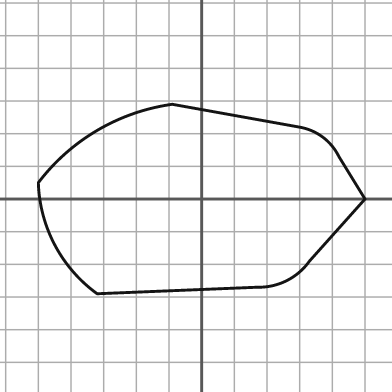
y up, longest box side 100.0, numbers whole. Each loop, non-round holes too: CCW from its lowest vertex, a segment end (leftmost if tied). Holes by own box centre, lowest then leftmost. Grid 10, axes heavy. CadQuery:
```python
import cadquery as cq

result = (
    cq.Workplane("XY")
    .moveTo(-32.0, -29.0)
    .lineTo(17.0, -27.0)
    .threePointArc((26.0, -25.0), (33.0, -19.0))
    .lineTo(50.0, 0.0)
    .lineTo(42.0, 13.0)
    .threePointArc((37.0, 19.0), (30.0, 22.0))
    .lineTo(-9.0, 29.0)
    .threePointArc((-32.0, 21.0), (-50.0, 5.0))
    .threePointArc((-45.0, -14.0), (-32.0, -29.0))
    .close()
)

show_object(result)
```